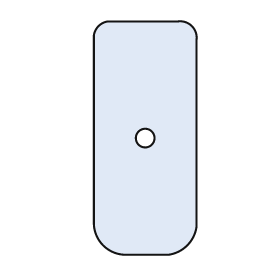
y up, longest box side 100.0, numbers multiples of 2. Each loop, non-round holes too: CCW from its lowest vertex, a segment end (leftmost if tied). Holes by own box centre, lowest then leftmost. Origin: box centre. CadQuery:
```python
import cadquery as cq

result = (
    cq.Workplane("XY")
    .moveTo(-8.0, -50.0)
    .lineTo(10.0, -50.0)
    .threePointArc((18.0, -46.0), (22.0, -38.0))
    .lineTo(22.0, 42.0)
    .threePointArc((20.0, 48.0), (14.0, 50.0))
    .lineTo(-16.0, 50.0)
    .threePointArc((-20.0, 48.0), (-22.0, 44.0))
    .lineTo(-22.0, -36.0)
    .threePointArc((-18.0, -46.0), (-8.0, -50.0))
    .close()
    .moveTo(0.0, 0.0)
    .circle(4.0)
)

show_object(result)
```